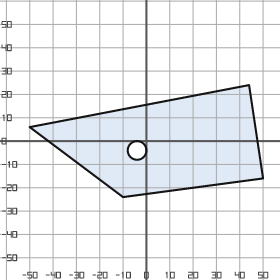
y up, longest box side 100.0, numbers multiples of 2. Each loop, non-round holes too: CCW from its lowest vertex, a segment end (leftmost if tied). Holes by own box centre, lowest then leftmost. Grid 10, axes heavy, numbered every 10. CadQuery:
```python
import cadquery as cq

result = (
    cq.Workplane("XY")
    .moveTo(-10.0, -24.0)
    .lineTo(50.0, -16.0)
    .lineTo(44.0, 24.0)
    .lineTo(-50.0, 6.0)
    .close()
    .moveTo(-4.0, -4.0)
    .circle(4.0)
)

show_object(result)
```